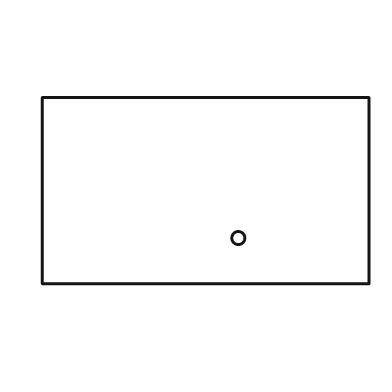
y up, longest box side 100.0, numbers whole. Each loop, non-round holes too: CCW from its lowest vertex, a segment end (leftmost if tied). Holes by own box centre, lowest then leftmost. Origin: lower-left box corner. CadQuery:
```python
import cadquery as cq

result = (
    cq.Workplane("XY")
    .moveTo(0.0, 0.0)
    .lineTo(100.0, 0.0)
    .lineTo(100.0, 57.0)
    .lineTo(0.0, 57.0)
    .close()
    .moveTo(60.0, 14.0)
    .circle(2.0)
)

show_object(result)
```